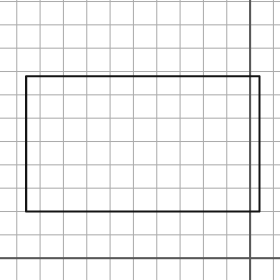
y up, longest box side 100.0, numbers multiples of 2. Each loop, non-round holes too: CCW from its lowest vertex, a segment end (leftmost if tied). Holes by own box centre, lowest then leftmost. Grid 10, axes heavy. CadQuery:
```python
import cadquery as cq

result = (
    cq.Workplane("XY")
    .moveTo(-96.0, 20.0)
    .lineTo(4.0, 20.0)
    .lineTo(4.0, 78.0)
    .lineTo(-96.0, 78.0)
    .close()
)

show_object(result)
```